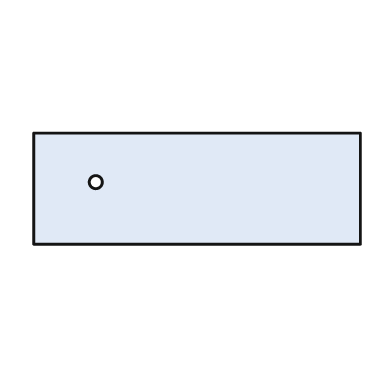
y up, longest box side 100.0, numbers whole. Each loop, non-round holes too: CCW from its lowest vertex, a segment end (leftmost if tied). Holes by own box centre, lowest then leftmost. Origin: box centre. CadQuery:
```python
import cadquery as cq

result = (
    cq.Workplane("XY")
    .moveTo(-50.0, -17.0)
    .lineTo(50.0, -17.0)
    .lineTo(50.0, 17.0)
    .lineTo(-50.0, 17.0)
    .close()
    .moveTo(-31.0, 2.0)
    .circle(2.0)
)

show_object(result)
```